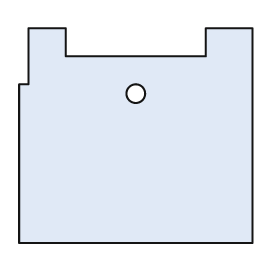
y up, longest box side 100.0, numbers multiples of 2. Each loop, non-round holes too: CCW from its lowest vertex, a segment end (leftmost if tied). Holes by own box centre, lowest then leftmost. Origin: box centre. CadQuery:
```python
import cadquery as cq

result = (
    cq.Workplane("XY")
    .moveTo(-50.0, -46.0)
    .lineTo(50.0, -46.0)
    .lineTo(50.0, 46.0)
    .lineTo(30.0, 46.0)
    .lineTo(30.0, 34.0)
    .lineTo(-30.0, 34.0)
    .lineTo(-30.0, 46.0)
    .lineTo(-46.0, 46.0)
    .lineTo(-46.0, 22.0)
    .lineTo(-50.0, 22.0)
    .close()
    .moveTo(0.0, 18.0)
    .circle(4.0)
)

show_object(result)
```